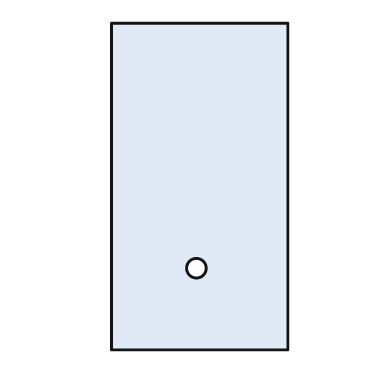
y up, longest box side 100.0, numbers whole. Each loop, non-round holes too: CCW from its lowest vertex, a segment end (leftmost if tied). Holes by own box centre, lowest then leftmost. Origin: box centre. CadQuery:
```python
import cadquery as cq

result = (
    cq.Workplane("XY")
    .moveTo(-27.0, -50.0)
    .lineTo(27.0, -50.0)
    .lineTo(27.0, 50.0)
    .lineTo(-27.0, 50.0)
    .close()
    .moveTo(-1.0, -25.0)
    .circle(3.0)
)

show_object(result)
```